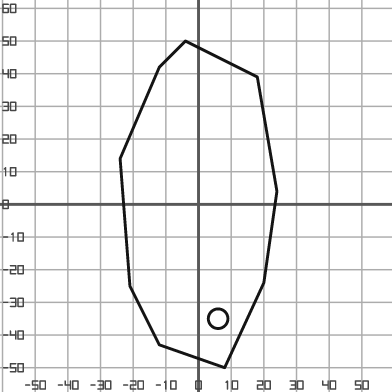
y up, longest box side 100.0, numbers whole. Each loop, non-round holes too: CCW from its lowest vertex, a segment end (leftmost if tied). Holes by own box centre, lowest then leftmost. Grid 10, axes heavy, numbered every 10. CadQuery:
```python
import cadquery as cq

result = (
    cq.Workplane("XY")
    .moveTo(8.0, -50.0)
    .lineTo(20.0, -24.0)
    .lineTo(24.0, 4.0)
    .lineTo(18.0, 39.0)
    .lineTo(-4.0, 50.0)
    .lineTo(-12.0, 42.0)
    .lineTo(-24.0, 14.0)
    .lineTo(-21.0, -25.0)
    .lineTo(-12.0, -43.0)
    .close()
    .moveTo(6.0, -35.0)
    .circle(3.0)
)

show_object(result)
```